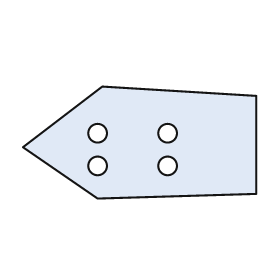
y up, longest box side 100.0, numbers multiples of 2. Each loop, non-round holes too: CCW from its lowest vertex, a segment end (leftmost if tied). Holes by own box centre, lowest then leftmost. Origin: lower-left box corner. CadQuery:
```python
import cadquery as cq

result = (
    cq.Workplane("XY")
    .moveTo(32.0, 0.0)
    .lineTo(100.0, 2.0)
    .lineTo(100.0, 44.0)
    .lineTo(34.0, 48.0)
    .lineTo(0.0, 22.0)
    .close()
    .moveTo(32.0, 14.0)
    .circle(4.0)
    .moveTo(62.0, 14.0)
    .circle(4.0)
    .moveTo(32.0, 28.0)
    .circle(4.0)
    .moveTo(62.0, 28.0)
    .circle(4.0)
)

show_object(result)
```